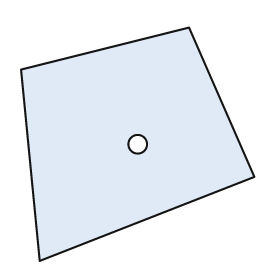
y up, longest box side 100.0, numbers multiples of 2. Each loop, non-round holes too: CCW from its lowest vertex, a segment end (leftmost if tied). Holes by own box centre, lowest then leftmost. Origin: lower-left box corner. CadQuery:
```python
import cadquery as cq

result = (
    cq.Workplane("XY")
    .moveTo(8.0, 0.0)
    .lineTo(100.0, 36.0)
    .lineTo(72.0, 100.0)
    .lineTo(0.0, 82.0)
    .close()
    .moveTo(50.0, 50.0)
    .circle(4.0)
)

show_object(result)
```